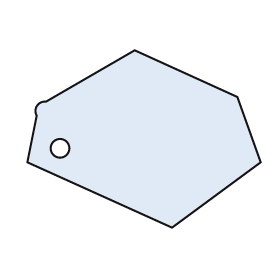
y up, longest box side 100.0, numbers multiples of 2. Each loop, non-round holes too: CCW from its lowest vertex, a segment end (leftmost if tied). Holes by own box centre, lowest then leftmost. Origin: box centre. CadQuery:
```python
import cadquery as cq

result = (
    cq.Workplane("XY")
    .moveTo(12.0, -38.0)
    .lineTo(50.0, -10.0)
    .lineTo(40.0, 18.0)
    .lineTo(-4.0, 38.0)
    .lineTo(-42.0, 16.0)
    .threePointArc((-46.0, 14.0), (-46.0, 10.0))
    .lineTo(-50.0, -10.0)
    .close()
    .moveTo(-36.0, -4.0)
    .circle(4.0)
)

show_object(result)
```